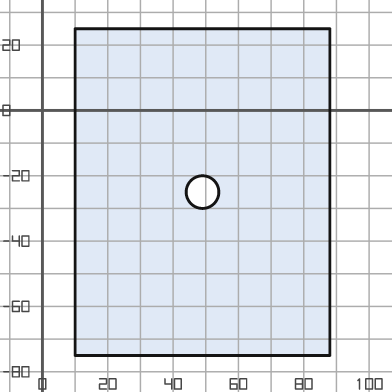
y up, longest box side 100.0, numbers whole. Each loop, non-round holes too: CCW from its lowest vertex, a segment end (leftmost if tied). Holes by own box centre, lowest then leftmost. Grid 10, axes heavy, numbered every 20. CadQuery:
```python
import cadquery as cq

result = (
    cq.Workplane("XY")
    .moveTo(10.0, -75.0)
    .lineTo(88.0, -75.0)
    .lineTo(88.0, 25.0)
    .lineTo(10.0, 25.0)
    .close()
    .moveTo(49.0, -25.0)
    .circle(5.0)
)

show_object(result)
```